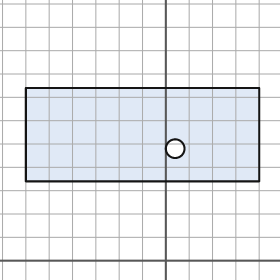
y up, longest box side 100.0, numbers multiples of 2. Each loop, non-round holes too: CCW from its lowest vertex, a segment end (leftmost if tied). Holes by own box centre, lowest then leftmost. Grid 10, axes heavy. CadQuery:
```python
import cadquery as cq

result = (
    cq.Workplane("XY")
    .moveTo(-60.0, 34.0)
    .lineTo(40.0, 34.0)
    .lineTo(40.0, 74.0)
    .lineTo(-60.0, 74.0)
    .close()
    .moveTo(4.0, 48.0)
    .circle(4.0)
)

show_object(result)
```